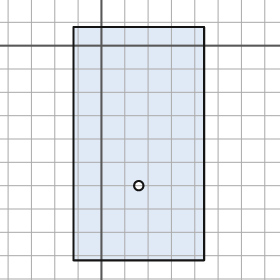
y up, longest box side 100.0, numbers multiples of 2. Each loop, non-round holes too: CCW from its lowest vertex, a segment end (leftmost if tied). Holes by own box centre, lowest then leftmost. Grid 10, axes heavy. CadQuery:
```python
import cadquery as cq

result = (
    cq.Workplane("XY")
    .moveTo(-12.0, -92.0)
    .lineTo(44.0, -92.0)
    .lineTo(44.0, 8.0)
    .lineTo(-12.0, 8.0)
    .close()
    .moveTo(16.0, -60.0)
    .circle(2.0)
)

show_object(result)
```